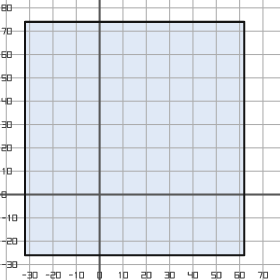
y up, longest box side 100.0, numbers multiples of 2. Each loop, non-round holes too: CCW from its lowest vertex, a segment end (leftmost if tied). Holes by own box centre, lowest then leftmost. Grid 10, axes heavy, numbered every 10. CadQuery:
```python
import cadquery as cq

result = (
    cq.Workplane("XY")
    .moveTo(-32.0, -26.0)
    .lineTo(62.0, -26.0)
    .lineTo(62.0, 74.0)
    .lineTo(-32.0, 74.0)
    .close()
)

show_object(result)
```